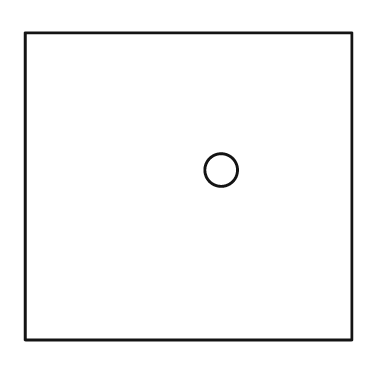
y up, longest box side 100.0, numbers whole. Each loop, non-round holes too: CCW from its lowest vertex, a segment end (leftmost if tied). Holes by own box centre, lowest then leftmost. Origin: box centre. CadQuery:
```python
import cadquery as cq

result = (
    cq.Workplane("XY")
    .moveTo(-50.0, -47.0)
    .lineTo(50.0, -47.0)
    .lineTo(50.0, 47.0)
    .lineTo(-50.0, 47.0)
    .close()
    .moveTo(10.0, 5.0)
    .circle(5.0)
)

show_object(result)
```